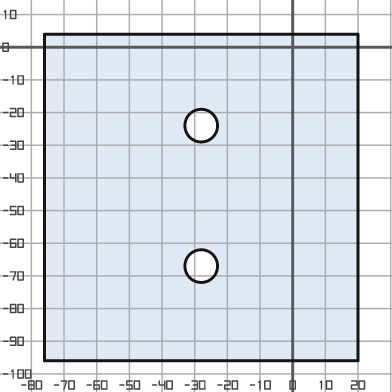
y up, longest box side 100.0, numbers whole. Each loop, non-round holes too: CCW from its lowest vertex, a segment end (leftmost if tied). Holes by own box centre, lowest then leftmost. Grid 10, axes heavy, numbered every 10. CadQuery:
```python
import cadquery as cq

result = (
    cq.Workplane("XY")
    .moveTo(-76.0, -96.0)
    .lineTo(20.0, -96.0)
    .lineTo(20.0, 4.0)
    .lineTo(-76.0, 4.0)
    .close()
    .moveTo(-28.0, -67.0)
    .circle(5.0)
    .moveTo(-28.0, -24.0)
    .circle(5.0)
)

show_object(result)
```